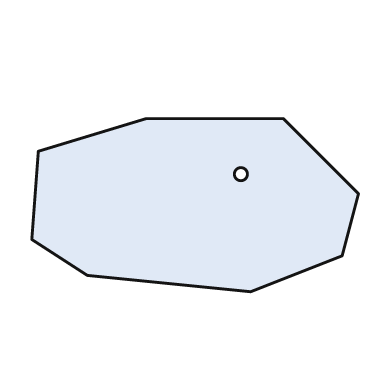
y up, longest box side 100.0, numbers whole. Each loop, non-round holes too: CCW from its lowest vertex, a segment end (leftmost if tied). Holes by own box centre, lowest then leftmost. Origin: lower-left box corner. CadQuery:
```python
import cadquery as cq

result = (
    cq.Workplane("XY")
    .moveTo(67.0, 0.0)
    .lineTo(95.0, 11.0)
    .lineTo(100.0, 30.0)
    .lineTo(77.0, 53.0)
    .lineTo(35.0, 53.0)
    .lineTo(2.0, 43.0)
    .lineTo(0.0, 16.0)
    .lineTo(17.0, 5.0)
    .close()
    .moveTo(64.0, 36.0)
    .circle(2.0)
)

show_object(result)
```